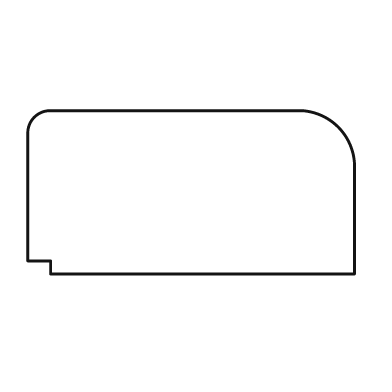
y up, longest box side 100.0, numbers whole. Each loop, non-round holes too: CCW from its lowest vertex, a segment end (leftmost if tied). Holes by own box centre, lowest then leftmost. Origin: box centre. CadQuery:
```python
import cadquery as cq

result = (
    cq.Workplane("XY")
    .moveTo(-43.0, -25.0)
    .lineTo(50.0, -25.0)
    .lineTo(50.0, 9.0)
    .threePointArc((45.0, 20.0), (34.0, 25.0))
    .lineTo(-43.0, 25.0)
    .threePointArc((-48.0, 23.0), (-50.0, 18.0))
    .lineTo(-50.0, -21.0)
    .lineTo(-43.0, -21.0)
    .close()
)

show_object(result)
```